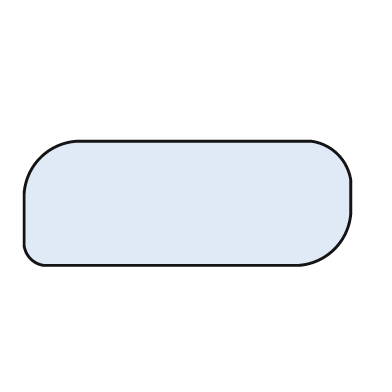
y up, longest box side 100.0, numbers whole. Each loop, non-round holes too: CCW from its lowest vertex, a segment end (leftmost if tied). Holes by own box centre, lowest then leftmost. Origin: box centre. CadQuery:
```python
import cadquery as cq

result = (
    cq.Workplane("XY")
    .moveTo(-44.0, -19.0)
    .lineTo(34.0, -19.0)
    .threePointArc((45.0, -14.0), (50.0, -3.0))
    .lineTo(50.0, 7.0)
    .threePointArc((46.0, 15.0), (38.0, 19.0))
    .lineTo(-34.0, 19.0)
    .threePointArc((-45.0, 14.0), (-50.0, 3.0))
    .lineTo(-50.0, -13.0)
    .threePointArc((-48.0, -17.0), (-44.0, -19.0))
    .close()
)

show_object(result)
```